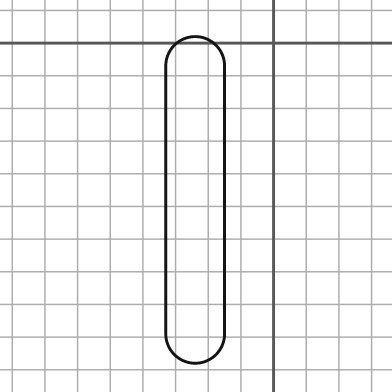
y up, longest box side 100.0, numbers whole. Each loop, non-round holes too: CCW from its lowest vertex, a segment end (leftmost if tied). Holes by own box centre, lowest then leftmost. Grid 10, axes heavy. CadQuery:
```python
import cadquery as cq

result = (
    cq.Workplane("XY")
    .moveTo(-33.0, -89.0)
    .threePointArc((-24.0, -98.0), (-15.0, -89.0))
    .lineTo(-15.0, -7.0)
    .threePointArc((-24.0, 2.0), (-33.0, -7.0))
    .close()
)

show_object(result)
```